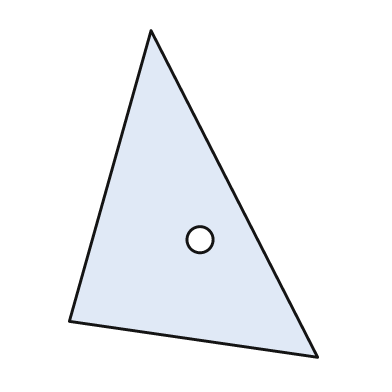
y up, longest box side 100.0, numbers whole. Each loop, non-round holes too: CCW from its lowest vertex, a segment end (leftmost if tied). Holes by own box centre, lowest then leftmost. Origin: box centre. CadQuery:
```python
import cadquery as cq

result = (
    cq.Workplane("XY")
    .moveTo(38.0, -50.0)
    .lineTo(-13.0, 50.0)
    .lineTo(-38.0, -39.0)
    .close()
    .moveTo(2.0, -14.0)
    .circle(4.0)
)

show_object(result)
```